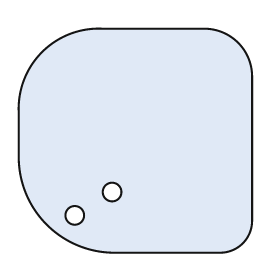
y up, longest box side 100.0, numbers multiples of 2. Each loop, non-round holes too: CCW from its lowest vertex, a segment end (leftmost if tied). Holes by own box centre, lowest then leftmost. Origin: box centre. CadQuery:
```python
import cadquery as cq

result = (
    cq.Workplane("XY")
    .moveTo(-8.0, -48.0)
    .lineTo(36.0, -48.0)
    .threePointArc((46.0, -44.0), (50.0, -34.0))
    .lineTo(50.0, 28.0)
    .threePointArc((44.0, 42.0), (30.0, 48.0))
    .lineTo(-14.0, 48.0)
    .threePointArc((-40.0, 38.0), (-50.0, 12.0))
    .lineTo(-50.0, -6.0)
    .threePointArc((-38.0, -36.0), (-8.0, -48.0))
    .close()
    .moveTo(-26.0, -32.0)
    .circle(4.0)
    .moveTo(-10.0, -22.0)
    .circle(4.0)
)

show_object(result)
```